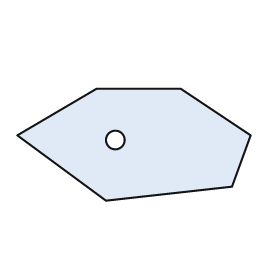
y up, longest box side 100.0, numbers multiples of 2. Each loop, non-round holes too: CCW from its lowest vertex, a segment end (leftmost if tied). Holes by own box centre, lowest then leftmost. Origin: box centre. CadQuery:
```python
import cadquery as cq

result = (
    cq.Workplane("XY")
    .moveTo(-12.0, -24.0)
    .lineTo(42.0, -18.0)
    .lineTo(50.0, 4.0)
    .lineTo(20.0, 24.0)
    .lineTo(-16.0, 24.0)
    .lineTo(-50.0, 4.0)
    .close()
    .moveTo(-8.0, 2.0)
    .circle(4.0)
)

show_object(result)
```